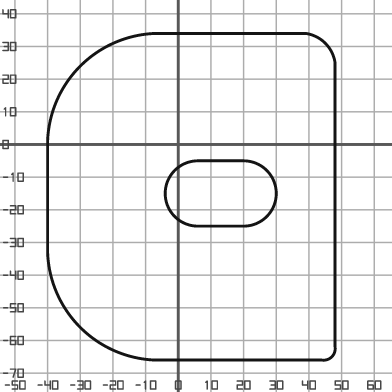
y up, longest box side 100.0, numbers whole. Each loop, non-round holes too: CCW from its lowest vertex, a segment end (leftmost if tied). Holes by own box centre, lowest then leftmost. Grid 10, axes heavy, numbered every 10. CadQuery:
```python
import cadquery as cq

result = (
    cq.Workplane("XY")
    .moveTo(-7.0, -66.0)
    .lineTo(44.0, -66.0)
    .threePointArc((47.0, -65.0), (48.0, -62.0))
    .lineTo(48.0, 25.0)
    .threePointArc((45.0, 31.0), (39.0, 34.0))
    .lineTo(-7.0, 34.0)
    .threePointArc((-30.0, 24.0), (-40.0, 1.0))
    .lineTo(-40.0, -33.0)
    .threePointArc((-30.0, -56.0), (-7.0, -66.0))
    .close()
    .moveTo(6.0, -25.0)
    .lineTo(20.0, -25.0)
    .threePointArc((30.0, -15.0), (20.0, -5.0))
    .lineTo(6.0, -5.0)
    .threePointArc((-4.0, -15.0), (6.0, -25.0))
    .close()
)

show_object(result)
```